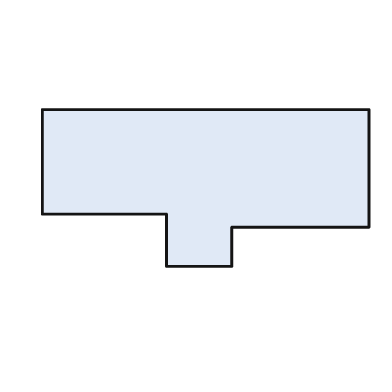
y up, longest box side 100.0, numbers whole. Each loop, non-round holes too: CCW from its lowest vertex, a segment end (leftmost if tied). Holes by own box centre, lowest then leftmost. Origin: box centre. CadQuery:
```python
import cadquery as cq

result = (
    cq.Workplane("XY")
    .moveTo(-12.0, -24.0)
    .lineTo(8.0, -24.0)
    .lineTo(8.0, -12.0)
    .lineTo(50.0, -12.0)
    .lineTo(50.0, 24.0)
    .lineTo(-50.0, 24.0)
    .lineTo(-50.0, -8.0)
    .lineTo(-12.0, -8.0)
    .close()
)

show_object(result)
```